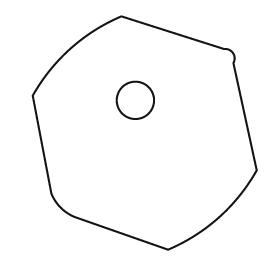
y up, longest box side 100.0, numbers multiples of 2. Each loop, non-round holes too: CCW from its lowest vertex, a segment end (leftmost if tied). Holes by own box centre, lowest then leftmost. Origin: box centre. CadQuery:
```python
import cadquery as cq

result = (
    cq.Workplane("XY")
    .moveTo(10.0, -50.0)
    .threePointArc((32.0, -36.0), (48.0, -16.0))
    .lineTo(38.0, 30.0)
    .threePointArc((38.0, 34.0), (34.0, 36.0))
    .lineTo(-10.0, 50.0)
    .threePointArc((-32.0, 36.0), (-48.0, 16.0))
    .lineTo(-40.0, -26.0)
    .threePointArc((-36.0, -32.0), (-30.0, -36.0))
    .close()
    .moveTo(-4.0, 14.0)
    .circle(8.0)
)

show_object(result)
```